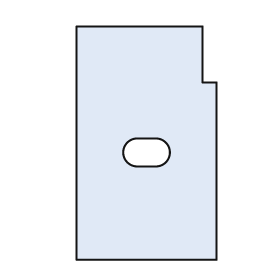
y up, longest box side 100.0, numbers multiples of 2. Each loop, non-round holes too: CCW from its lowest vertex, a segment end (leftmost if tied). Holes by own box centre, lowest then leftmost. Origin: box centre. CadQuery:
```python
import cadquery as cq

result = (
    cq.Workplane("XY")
    .moveTo(-30.0, -50.0)
    .lineTo(30.0, -50.0)
    .lineTo(30.0, 26.0)
    .lineTo(24.0, 26.0)
    .lineTo(24.0, 50.0)
    .lineTo(-30.0, 50.0)
    .close()
    .moveTo(-4.0, -10.0)
    .lineTo(4.0, -10.0)
    .threePointArc((10.0, -4.0), (4.0, 2.0))
    .lineTo(-4.0, 2.0)
    .threePointArc((-10.0, -4.0), (-4.0, -10.0))
    .close()
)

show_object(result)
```